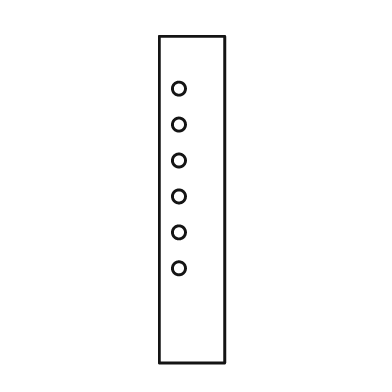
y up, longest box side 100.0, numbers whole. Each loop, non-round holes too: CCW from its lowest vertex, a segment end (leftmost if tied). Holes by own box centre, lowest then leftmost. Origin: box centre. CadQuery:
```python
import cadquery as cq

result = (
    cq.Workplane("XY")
    .moveTo(-10.0, -50.0)
    .lineTo(10.0, -50.0)
    .lineTo(10.0, 50.0)
    .lineTo(-10.0, 50.0)
    .close()
    .moveTo(-4.0, -21.0)
    .circle(2.0)
    .moveTo(-4.0, -10.0)
    .circle(2.0)
    .moveTo(-4.0, 1.0)
    .circle(2.0)
    .moveTo(-4.0, 12.0)
    .circle(2.0)
    .moveTo(-4.0, 23.0)
    .circle(2.0)
    .moveTo(-4.0, 34.0)
    .circle(2.0)
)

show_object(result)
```